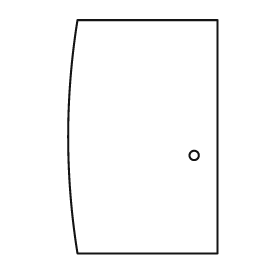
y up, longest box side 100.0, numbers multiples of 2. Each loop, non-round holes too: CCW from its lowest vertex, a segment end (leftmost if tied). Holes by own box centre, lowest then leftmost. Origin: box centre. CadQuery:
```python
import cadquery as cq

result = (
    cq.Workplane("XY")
    .moveTo(-28.0, -50.0)
    .lineTo(32.0, -50.0)
    .lineTo(32.0, 50.0)
    .lineTo(-28.0, 50.0)
    .threePointArc((-32.0, 0.0), (-28.0, -50.0))
    .close()
    .moveTo(22.0, -8.0)
    .circle(2.0)
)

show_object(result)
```